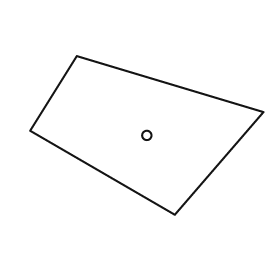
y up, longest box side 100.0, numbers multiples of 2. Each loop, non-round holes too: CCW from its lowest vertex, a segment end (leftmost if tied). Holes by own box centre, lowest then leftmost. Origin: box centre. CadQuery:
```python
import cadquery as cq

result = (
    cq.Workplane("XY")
    .moveTo(12.0, -34.0)
    .lineTo(50.0, 10.0)
    .lineTo(-30.0, 34.0)
    .lineTo(-50.0, 2.0)
    .close()
    .moveTo(0.0, 0.0)
    .circle(2.0)
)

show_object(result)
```